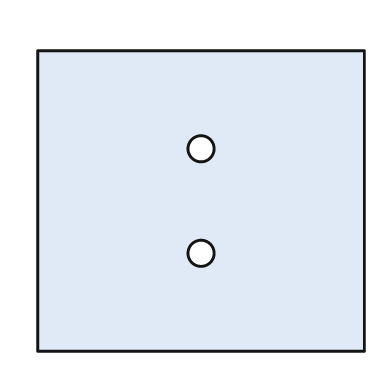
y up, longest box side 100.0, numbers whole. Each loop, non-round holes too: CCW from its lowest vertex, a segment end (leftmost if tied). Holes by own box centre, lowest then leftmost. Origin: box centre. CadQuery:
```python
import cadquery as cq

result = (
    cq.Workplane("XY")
    .moveTo(-50.0, -46.0)
    .lineTo(50.0, -46.0)
    .lineTo(50.0, 46.0)
    .lineTo(-50.0, 46.0)
    .close()
    .moveTo(0.0, -16.0)
    .circle(4.0)
    .moveTo(0.0, 16.0)
    .circle(4.0)
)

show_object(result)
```